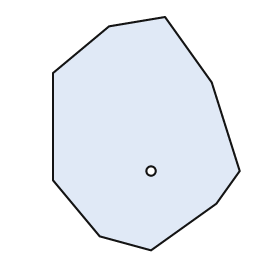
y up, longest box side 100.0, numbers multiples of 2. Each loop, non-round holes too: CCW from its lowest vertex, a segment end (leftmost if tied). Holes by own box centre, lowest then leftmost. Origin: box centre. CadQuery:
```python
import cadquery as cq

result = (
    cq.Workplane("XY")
    .moveTo(2.0, -50.0)
    .lineTo(30.0, -30.0)
    .lineTo(40.0, -16.0)
    .lineTo(28.0, 22.0)
    .lineTo(8.0, 50.0)
    .lineTo(-16.0, 46.0)
    .lineTo(-40.0, 26.0)
    .lineTo(-40.0, -20.0)
    .lineTo(-20.0, -44.0)
    .close()
    .moveTo(2.0, -16.0)
    .circle(2.0)
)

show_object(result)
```